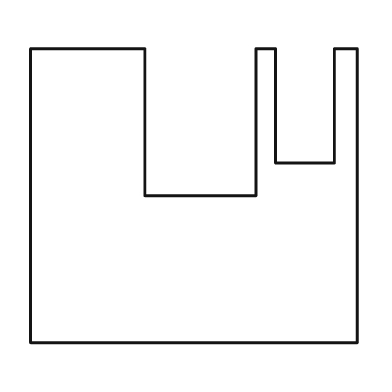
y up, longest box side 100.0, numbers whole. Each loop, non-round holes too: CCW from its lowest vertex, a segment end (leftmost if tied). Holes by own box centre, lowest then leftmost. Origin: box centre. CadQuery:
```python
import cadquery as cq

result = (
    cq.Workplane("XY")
    .moveTo(-50.0, -45.0)
    .lineTo(50.0, -45.0)
    .lineTo(50.0, 45.0)
    .lineTo(43.0, 45.0)
    .lineTo(43.0, 10.0)
    .lineTo(25.0, 10.0)
    .lineTo(25.0, 45.0)
    .lineTo(19.0, 45.0)
    .lineTo(19.0, 0.0)
    .lineTo(-15.0, 0.0)
    .lineTo(-15.0, 45.0)
    .lineTo(-50.0, 45.0)
    .close()
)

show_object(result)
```